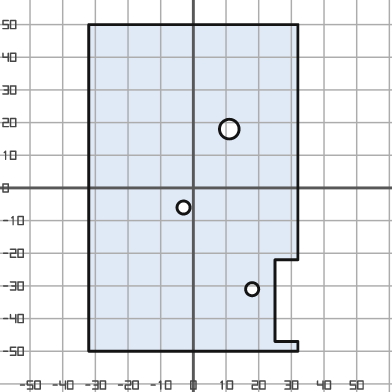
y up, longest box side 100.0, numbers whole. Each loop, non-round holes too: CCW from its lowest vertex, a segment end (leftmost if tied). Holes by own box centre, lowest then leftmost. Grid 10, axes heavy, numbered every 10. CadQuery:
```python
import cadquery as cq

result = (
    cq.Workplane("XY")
    .moveTo(-32.0, -50.0)
    .lineTo(32.0, -50.0)
    .lineTo(32.0, -47.0)
    .lineTo(25.0, -47.0)
    .lineTo(25.0, -22.0)
    .lineTo(32.0, -22.0)
    .lineTo(32.0, 50.0)
    .lineTo(-32.0, 50.0)
    .close()
    .moveTo(18.0, -31.0)
    .circle(2.0)
    .moveTo(-3.0, -6.0)
    .circle(2.0)
    .moveTo(11.0, 18.0)
    .circle(3.0)
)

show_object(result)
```